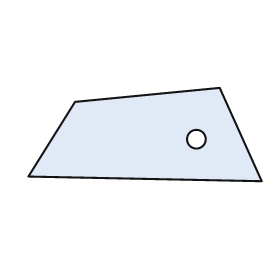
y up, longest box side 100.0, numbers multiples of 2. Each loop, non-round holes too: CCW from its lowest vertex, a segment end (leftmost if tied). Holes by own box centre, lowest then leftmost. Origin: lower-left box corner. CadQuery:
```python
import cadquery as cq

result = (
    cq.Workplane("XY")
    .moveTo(100.0, 0.0)
    .lineTo(82.0, 40.0)
    .lineTo(20.0, 34.0)
    .lineTo(0.0, 2.0)
    .close()
    .moveTo(72.0, 18.0)
    .circle(4.0)
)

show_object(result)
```